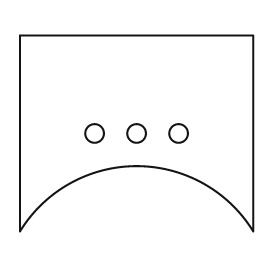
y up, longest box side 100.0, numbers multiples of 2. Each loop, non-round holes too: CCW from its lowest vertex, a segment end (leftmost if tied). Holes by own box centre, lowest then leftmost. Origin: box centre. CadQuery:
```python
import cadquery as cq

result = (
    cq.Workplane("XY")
    .moveTo(-50.0, -42.0)
    .threePointArc((0.0, -14.0), (50.0, -42.0))
    .lineTo(50.0, 42.0)
    .lineTo(-50.0, 42.0)
    .close()
    .moveTo(-18.0, 0.0)
    .circle(4.0)
    .moveTo(0.0, 0.0)
    .circle(4.0)
    .moveTo(18.0, 0.0)
    .circle(4.0)
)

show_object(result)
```